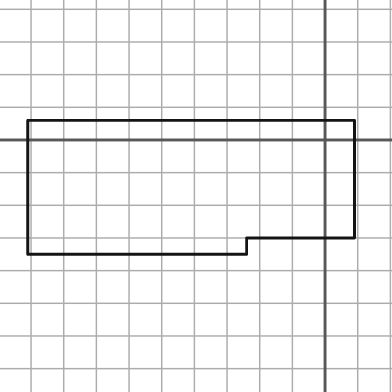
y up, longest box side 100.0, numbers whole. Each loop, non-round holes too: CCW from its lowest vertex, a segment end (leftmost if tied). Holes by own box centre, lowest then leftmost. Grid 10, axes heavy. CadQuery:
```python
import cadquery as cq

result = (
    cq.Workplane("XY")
    .moveTo(-91.0, -35.0)
    .lineTo(-24.0, -35.0)
    .lineTo(-24.0, -30.0)
    .lineTo(9.0, -30.0)
    .lineTo(9.0, 6.0)
    .lineTo(-91.0, 6.0)
    .close()
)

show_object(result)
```